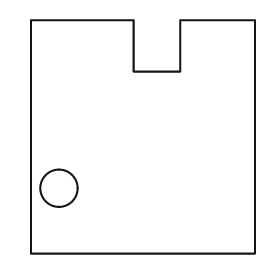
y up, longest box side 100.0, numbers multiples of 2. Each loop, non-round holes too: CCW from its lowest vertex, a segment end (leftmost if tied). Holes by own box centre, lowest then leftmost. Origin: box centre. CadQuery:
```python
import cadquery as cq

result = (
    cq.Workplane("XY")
    .moveTo(-48.0, -50.0)
    .lineTo(48.0, -50.0)
    .lineTo(48.0, 50.0)
    .lineTo(16.0, 50.0)
    .lineTo(16.0, 28.0)
    .lineTo(-4.0, 28.0)
    .lineTo(-4.0, 50.0)
    .lineTo(-48.0, 50.0)
    .close()
    .moveTo(-36.0, -22.0)
    .circle(8.0)
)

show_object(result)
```